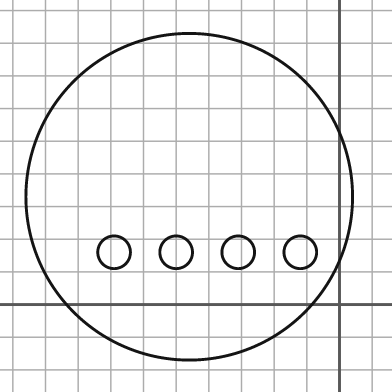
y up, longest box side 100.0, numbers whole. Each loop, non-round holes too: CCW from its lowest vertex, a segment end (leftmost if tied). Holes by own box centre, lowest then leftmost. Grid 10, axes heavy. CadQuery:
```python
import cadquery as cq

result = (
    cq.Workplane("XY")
    .moveTo(-46.0, 33.0)
    .circle(50.0)
    .moveTo(-69.0, 16.0)
    .circle(5.0)
    .moveTo(-50.0, 16.0)
    .circle(5.0)
    .moveTo(-31.0, 16.0)
    .circle(5.0)
    .moveTo(-12.0, 16.0)
    .circle(5.0)
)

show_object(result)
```